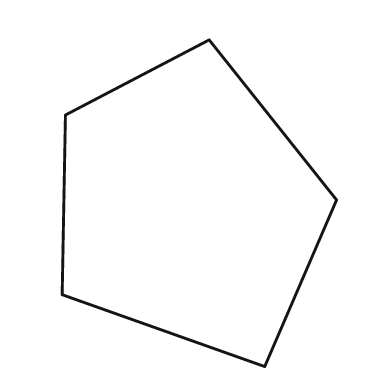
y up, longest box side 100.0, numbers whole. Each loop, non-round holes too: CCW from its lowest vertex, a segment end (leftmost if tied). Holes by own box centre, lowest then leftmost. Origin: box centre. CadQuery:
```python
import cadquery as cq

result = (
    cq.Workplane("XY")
    .moveTo(20.0, -50.0)
    .lineTo(42.0, 1.0)
    .lineTo(3.0, 50.0)
    .lineTo(-41.0, 27.0)
    .lineTo(-42.0, -28.0)
    .close()
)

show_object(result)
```